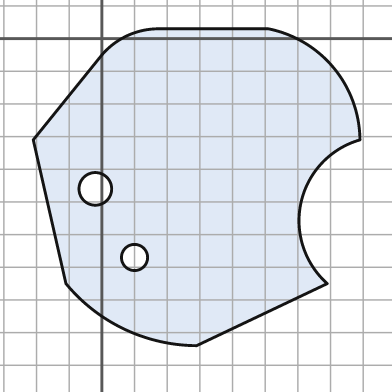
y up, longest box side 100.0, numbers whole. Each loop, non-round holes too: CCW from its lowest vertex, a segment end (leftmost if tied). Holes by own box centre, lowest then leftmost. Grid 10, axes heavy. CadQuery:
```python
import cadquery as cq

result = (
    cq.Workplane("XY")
    .moveTo(29.0, -94.0)
    .lineTo(69.0, -75.0)
    .threePointArc((61.0, -50.0), (79.0, -31.0))
    .threePointArc((71.0, -9.0), (51.0, 3.0))
    .lineTo(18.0, 3.0)
    .threePointArc((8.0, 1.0), (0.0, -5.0))
    .lineTo(-21.0, -31.0)
    .lineTo(-11.0, -75.0)
    .threePointArc((7.0, -89.0), (29.0, -94.0))
    .close()
    .moveTo(10.0, -67.0)
    .circle(4.0)
    .moveTo(-2.0, -46.0)
    .circle(5.0)
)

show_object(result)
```